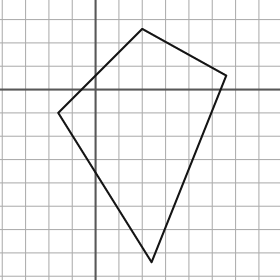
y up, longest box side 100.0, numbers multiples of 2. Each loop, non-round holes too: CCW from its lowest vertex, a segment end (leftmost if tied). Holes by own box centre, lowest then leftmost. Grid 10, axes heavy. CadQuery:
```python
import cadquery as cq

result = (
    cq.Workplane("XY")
    .moveTo(24.0, -74.0)
    .lineTo(56.0, 6.0)
    .lineTo(20.0, 26.0)
    .lineTo(-16.0, -10.0)
    .close()
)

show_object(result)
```